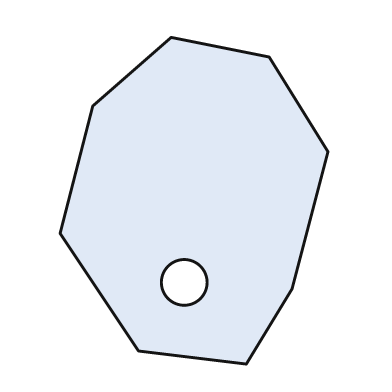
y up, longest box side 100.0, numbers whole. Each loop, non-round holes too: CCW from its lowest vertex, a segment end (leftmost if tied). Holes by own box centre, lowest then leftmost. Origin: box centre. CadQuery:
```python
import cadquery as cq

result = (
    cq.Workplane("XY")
    .moveTo(16.0, -50.0)
    .lineTo(30.0, -27.0)
    .lineTo(41.0, 15.0)
    .lineTo(23.0, 44.0)
    .lineTo(-7.0, 50.0)
    .lineTo(-31.0, 29.0)
    .lineTo(-41.0, -10.0)
    .lineTo(-17.0, -46.0)
    .close()
    .moveTo(-3.0, -25.0)
    .circle(7.0)
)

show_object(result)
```